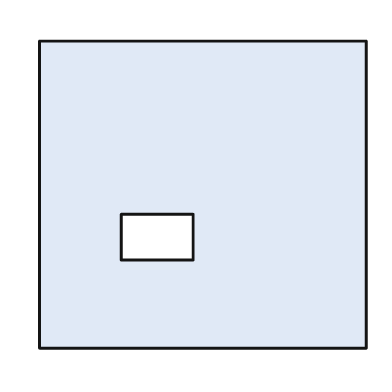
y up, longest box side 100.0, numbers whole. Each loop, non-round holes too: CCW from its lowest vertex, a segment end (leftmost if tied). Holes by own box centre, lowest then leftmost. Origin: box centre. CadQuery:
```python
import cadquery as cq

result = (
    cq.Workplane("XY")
    .moveTo(-50.0, -47.0)
    .lineTo(50.0, -47.0)
    .lineTo(50.0, 47.0)
    .lineTo(-50.0, 47.0)
    .close()
    .moveTo(-25.0, -20.0)
    .lineTo(-3.0, -20.0)
    .lineTo(-3.0, -6.0)
    .lineTo(-25.0, -6.0)
    .close()
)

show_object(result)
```